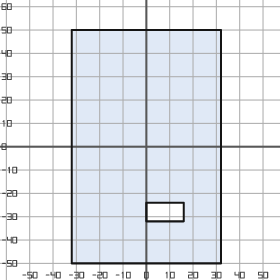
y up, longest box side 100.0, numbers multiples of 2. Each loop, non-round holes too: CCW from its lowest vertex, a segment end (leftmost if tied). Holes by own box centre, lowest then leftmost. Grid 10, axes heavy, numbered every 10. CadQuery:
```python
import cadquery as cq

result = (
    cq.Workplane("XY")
    .moveTo(-32.0, -50.0)
    .lineTo(32.0, -50.0)
    .lineTo(32.0, 50.0)
    .lineTo(-32.0, 50.0)
    .close()
    .moveTo(0.0, -32.0)
    .lineTo(16.0, -32.0)
    .lineTo(16.0, -24.0)
    .lineTo(0.0, -24.0)
    .close()
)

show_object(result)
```